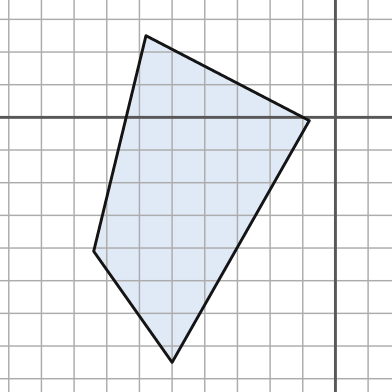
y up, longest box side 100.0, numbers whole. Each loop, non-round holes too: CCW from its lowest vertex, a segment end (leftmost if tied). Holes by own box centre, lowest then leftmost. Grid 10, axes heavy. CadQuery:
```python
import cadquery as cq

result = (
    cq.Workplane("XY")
    .moveTo(-50.0, -75.0)
    .lineTo(-8.0, -1.0)
    .lineTo(-58.0, 25.0)
    .lineTo(-74.0, -41.0)
    .close()
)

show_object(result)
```